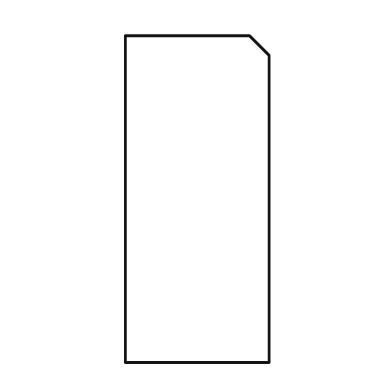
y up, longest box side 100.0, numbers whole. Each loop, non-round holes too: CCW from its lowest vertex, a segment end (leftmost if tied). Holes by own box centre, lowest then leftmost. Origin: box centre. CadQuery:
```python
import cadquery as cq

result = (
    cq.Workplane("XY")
    .moveTo(-22.0, -50.0)
    .lineTo(22.0, -50.0)
    .lineTo(22.0, 44.0)
    .lineTo(16.0, 50.0)
    .lineTo(-22.0, 50.0)
    .close()
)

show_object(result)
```